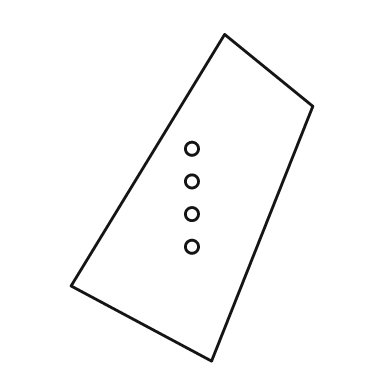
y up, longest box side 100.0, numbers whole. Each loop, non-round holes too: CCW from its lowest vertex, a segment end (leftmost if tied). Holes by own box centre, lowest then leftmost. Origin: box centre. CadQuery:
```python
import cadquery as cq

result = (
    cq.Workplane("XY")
    .moveTo(6.0, -50.0)
    .lineTo(37.0, 28.0)
    .lineTo(10.0, 50.0)
    .lineTo(-37.0, -27.0)
    .close()
    .moveTo(0.0, -15.0)
    .circle(2.0)
    .moveTo(0.0, -5.0)
    .circle(2.0)
    .moveTo(0.0, 5.0)
    .circle(2.0)
    .moveTo(0.0, 15.0)
    .circle(2.0)
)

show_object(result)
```